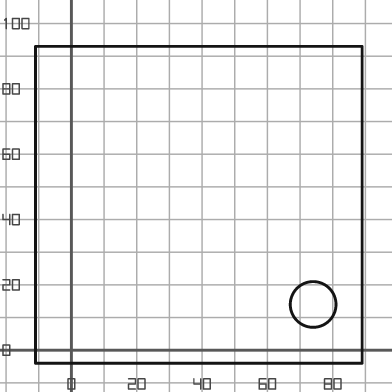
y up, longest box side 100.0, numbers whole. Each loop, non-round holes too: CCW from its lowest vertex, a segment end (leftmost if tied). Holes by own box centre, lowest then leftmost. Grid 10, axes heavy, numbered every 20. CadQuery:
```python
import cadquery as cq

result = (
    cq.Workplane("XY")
    .moveTo(-11.0, -4.0)
    .lineTo(89.0, -4.0)
    .lineTo(89.0, 93.0)
    .lineTo(-11.0, 93.0)
    .close()
    .moveTo(74.0, 14.0)
    .circle(7.0)
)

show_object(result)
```